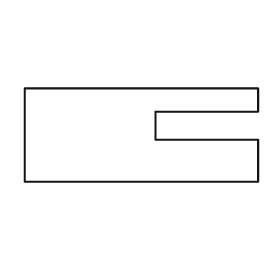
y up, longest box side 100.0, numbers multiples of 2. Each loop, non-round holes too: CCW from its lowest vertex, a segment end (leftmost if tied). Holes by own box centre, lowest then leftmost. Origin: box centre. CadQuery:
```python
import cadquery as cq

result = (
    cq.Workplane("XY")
    .moveTo(-50.0, -20.0)
    .lineTo(50.0, -20.0)
    .lineTo(50.0, -2.0)
    .lineTo(6.0, -2.0)
    .lineTo(6.0, 10.0)
    .lineTo(50.0, 10.0)
    .lineTo(50.0, 20.0)
    .lineTo(-50.0, 20.0)
    .close()
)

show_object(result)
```